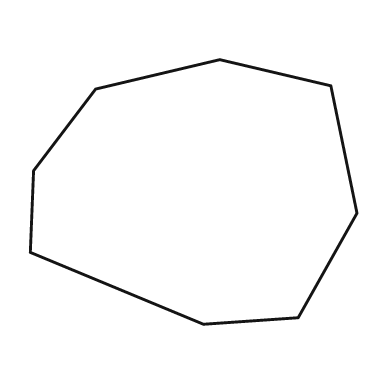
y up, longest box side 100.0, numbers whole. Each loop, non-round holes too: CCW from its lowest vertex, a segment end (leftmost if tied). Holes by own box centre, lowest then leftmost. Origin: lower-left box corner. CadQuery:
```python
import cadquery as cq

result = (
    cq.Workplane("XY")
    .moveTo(53.0, 0.0)
    .lineTo(82.0, 2.0)
    .lineTo(100.0, 34.0)
    .lineTo(92.0, 73.0)
    .lineTo(58.0, 81.0)
    .lineTo(20.0, 72.0)
    .lineTo(1.0, 47.0)
    .lineTo(0.0, 22.0)
    .close()
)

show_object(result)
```